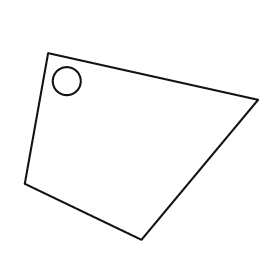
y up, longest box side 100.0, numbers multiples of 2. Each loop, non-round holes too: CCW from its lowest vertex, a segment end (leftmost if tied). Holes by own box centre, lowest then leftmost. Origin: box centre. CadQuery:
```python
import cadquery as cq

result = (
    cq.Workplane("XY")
    .moveTo(0.0, -40.0)
    .lineTo(50.0, 20.0)
    .lineTo(-40.0, 40.0)
    .lineTo(-50.0, -16.0)
    .close()
    .moveTo(-32.0, 28.0)
    .circle(6.0)
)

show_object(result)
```